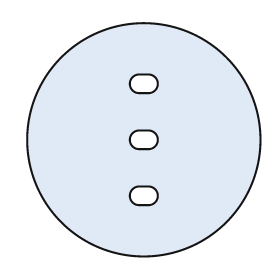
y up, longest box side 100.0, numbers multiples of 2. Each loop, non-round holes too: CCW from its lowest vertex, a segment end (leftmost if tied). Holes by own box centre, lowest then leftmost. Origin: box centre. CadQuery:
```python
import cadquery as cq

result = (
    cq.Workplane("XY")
    .moveTo(0.0, 0.0)
    .circle(50.0)
    .moveTo(-2.0, -28.0)
    .lineTo(2.0, -28.0)
    .threePointArc((6.0, -24.0), (2.0, -20.0))
    .lineTo(-2.0, -20.0)
    .threePointArc((-6.0, -24.0), (-2.0, -28.0))
    .close()
    .moveTo(-2.0, -4.0)
    .lineTo(2.0, -4.0)
    .threePointArc((6.0, 0.0), (2.0, 4.0))
    .lineTo(-2.0, 4.0)
    .threePointArc((-6.0, 0.0), (-2.0, -4.0))
    .close()
    .moveTo(-2.0, 20.0)
    .lineTo(2.0, 20.0)
    .threePointArc((6.0, 24.0), (2.0, 28.0))
    .lineTo(-2.0, 28.0)
    .threePointArc((-6.0, 24.0), (-2.0, 20.0))
    .close()
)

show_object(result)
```